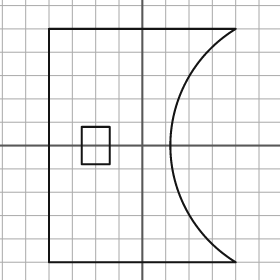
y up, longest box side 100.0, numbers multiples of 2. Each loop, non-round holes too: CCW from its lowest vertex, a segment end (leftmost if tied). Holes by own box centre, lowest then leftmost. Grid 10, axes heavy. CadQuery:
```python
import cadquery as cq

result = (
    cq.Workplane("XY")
    .moveTo(-40.0, -50.0)
    .lineTo(40.0, -50.0)
    .threePointArc((12.0, 0.0), (40.0, 50.0))
    .lineTo(-40.0, 50.0)
    .close()
    .moveTo(-26.0, -8.0)
    .lineTo(-14.0, -8.0)
    .lineTo(-14.0, 8.0)
    .lineTo(-26.0, 8.0)
    .close()
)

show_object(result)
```